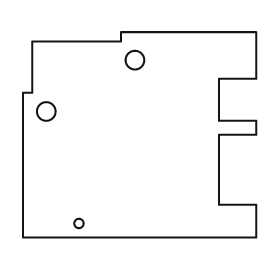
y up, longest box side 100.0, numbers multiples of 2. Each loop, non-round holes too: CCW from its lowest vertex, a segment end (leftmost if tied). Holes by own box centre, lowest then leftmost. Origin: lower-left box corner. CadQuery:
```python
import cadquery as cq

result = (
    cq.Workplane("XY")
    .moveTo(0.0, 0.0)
    .lineTo(100.0, 0.0)
    .lineTo(100.0, 14.0)
    .lineTo(84.0, 14.0)
    .lineTo(84.0, 44.0)
    .lineTo(100.0, 44.0)
    .lineTo(100.0, 50.0)
    .lineTo(84.0, 50.0)
    .lineTo(84.0, 68.0)
    .lineTo(100.0, 68.0)
    .lineTo(100.0, 88.0)
    .lineTo(42.0, 88.0)
    .lineTo(42.0, 84.0)
    .lineTo(4.0, 84.0)
    .lineTo(4.0, 62.0)
    .lineTo(0.0, 62.0)
    .close()
    .moveTo(24.0, 6.0)
    .circle(2.0)
    .moveTo(10.0, 54.0)
    .circle(4.0)
    .moveTo(48.0, 76.0)
    .circle(4.0)
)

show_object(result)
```